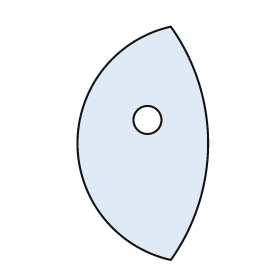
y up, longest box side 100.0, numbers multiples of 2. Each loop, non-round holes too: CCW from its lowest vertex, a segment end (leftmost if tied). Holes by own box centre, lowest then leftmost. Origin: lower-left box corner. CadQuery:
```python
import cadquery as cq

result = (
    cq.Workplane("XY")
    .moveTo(40.0, 0.0)
    .threePointArc((56.0, 50.0), (40.0, 100.0))
    .threePointArc((0.0, 50.0), (40.0, 0.0))
    .close()
    .moveTo(30.0, 60.0)
    .circle(6.0)
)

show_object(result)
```